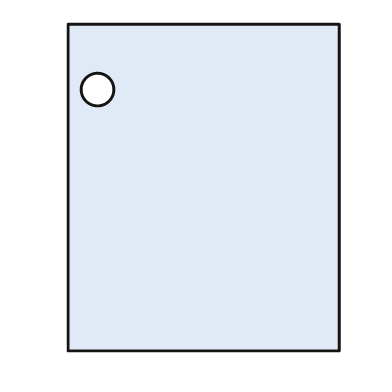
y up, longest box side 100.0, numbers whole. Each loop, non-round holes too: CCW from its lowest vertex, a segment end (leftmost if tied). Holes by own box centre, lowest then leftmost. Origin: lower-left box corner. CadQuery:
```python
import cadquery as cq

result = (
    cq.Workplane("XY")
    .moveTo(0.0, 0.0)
    .lineTo(83.0, 0.0)
    .lineTo(83.0, 100.0)
    .lineTo(0.0, 100.0)
    .close()
    .moveTo(9.0, 80.0)
    .circle(5.0)
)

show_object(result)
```